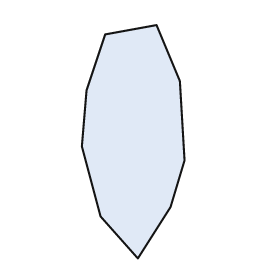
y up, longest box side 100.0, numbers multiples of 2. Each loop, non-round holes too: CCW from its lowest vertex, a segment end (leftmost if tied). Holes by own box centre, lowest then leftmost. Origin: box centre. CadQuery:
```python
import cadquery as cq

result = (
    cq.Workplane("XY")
    .moveTo(2.0, -50.0)
    .lineTo(16.0, -28.0)
    .lineTo(22.0, -8.0)
    .lineTo(20.0, 26.0)
    .lineTo(10.0, 50.0)
    .lineTo(-12.0, 46.0)
    .lineTo(-20.0, 22.0)
    .lineTo(-22.0, -2.0)
    .lineTo(-14.0, -32.0)
    .close()
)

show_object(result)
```